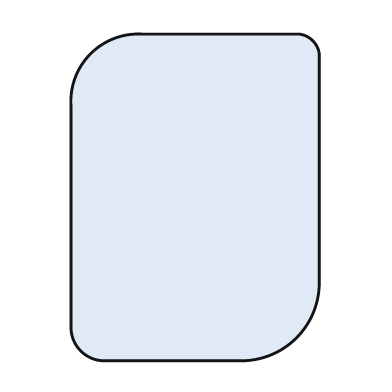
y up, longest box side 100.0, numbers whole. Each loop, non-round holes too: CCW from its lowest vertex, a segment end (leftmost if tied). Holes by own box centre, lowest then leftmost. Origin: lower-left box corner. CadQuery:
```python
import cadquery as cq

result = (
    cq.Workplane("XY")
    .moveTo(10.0, 0.0)
    .lineTo(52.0, 0.0)
    .threePointArc((69.0, 7.0), (76.0, 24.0))
    .lineTo(76.0, 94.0)
    .threePointArc((74.0, 98.0), (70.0, 100.0))
    .lineTo(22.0, 100.0)
    .threePointArc((6.0, 94.0), (0.0, 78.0))
    .lineTo(0.0, 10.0)
    .threePointArc((3.0, 3.0), (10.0, 0.0))
    .close()
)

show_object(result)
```